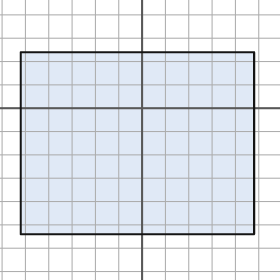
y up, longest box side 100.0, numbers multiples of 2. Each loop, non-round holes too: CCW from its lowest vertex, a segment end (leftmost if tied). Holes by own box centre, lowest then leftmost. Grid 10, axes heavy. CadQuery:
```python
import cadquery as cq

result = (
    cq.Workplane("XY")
    .moveTo(-52.0, -54.0)
    .lineTo(48.0, -54.0)
    .lineTo(48.0, 24.0)
    .lineTo(-52.0, 24.0)
    .close()
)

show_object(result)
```